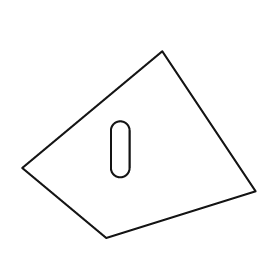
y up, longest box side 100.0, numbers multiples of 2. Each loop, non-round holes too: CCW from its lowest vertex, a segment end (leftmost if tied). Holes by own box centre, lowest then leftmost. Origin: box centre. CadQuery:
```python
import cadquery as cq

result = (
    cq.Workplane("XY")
    .moveTo(-14.0, -40.0)
    .lineTo(50.0, -20.0)
    .lineTo(10.0, 40.0)
    .lineTo(-50.0, -10.0)
    .close()
    .moveTo(-12.0, -10.0)
    .threePointArc((-8.0, -14.0), (-4.0, -10.0))
    .lineTo(-4.0, 6.0)
    .threePointArc((-8.0, 10.0), (-12.0, 6.0))
    .close()
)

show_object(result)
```